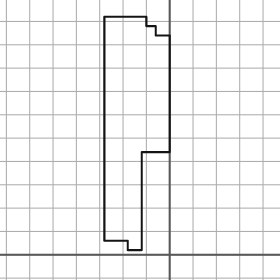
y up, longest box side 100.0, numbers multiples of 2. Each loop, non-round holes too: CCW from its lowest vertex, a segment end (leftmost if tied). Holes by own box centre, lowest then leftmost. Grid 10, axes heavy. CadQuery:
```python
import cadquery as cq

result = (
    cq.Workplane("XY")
    .moveTo(-18.0, 2.0)
    .lineTo(-12.0, 2.0)
    .lineTo(-12.0, 44.0)
    .lineTo(0.0, 44.0)
    .lineTo(0.0, 94.0)
    .lineTo(-6.0, 94.0)
    .lineTo(-6.0, 98.0)
    .lineTo(-10.0, 98.0)
    .lineTo(-10.0, 102.0)
    .lineTo(-28.0, 102.0)
    .lineTo(-28.0, 6.0)
    .lineTo(-18.0, 6.0)
    .close()
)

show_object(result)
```